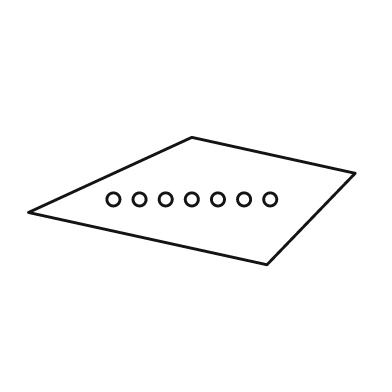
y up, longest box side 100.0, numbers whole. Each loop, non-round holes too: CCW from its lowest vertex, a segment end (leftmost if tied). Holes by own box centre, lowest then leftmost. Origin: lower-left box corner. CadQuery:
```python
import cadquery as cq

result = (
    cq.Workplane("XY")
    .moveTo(73.0, 0.0)
    .lineTo(100.0, 28.0)
    .lineTo(50.0, 39.0)
    .lineTo(0.0, 16.0)
    .close()
    .moveTo(26.0, 20.0)
    .circle(2.0)
    .moveTo(34.0, 20.0)
    .circle(2.0)
    .moveTo(42.0, 20.0)
    .circle(2.0)
    .moveTo(50.0, 20.0)
    .circle(2.0)
    .moveTo(58.0, 20.0)
    .circle(2.0)
    .moveTo(66.0, 20.0)
    .circle(2.0)
    .moveTo(74.0, 20.0)
    .circle(2.0)
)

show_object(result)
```